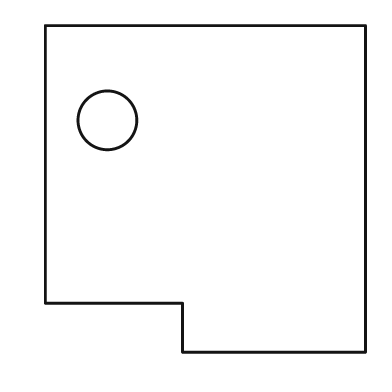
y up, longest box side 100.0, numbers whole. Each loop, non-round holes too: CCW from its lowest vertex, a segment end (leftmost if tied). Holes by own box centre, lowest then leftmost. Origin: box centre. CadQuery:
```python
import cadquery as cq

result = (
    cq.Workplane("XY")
    .moveTo(-7.0, -50.0)
    .lineTo(49.0, -50.0)
    .lineTo(49.0, 50.0)
    .lineTo(-49.0, 50.0)
    .lineTo(-49.0, -35.0)
    .lineTo(-7.0, -35.0)
    .close()
    .moveTo(-30.0, 21.0)
    .circle(9.0)
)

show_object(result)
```